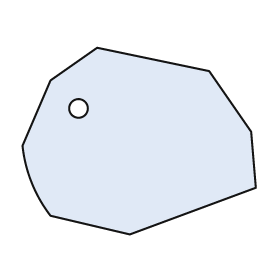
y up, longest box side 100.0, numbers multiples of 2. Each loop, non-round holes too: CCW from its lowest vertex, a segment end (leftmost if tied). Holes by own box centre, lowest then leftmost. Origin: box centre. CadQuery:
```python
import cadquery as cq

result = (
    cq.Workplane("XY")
    .moveTo(-4.0, -40.0)
    .lineTo(50.0, -20.0)
    .lineTo(48.0, 4.0)
    .lineTo(30.0, 30.0)
    .lineTo(-18.0, 40.0)
    .lineTo(-38.0, 26.0)
    .lineTo(-50.0, -2.0)
    .threePointArc((-46.0, -18.0), (-38.0, -32.0))
    .close()
    .moveTo(-26.0, 14.0)
    .circle(4.0)
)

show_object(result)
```